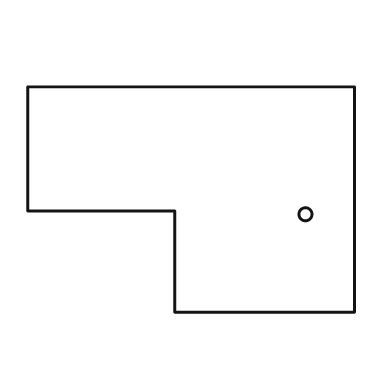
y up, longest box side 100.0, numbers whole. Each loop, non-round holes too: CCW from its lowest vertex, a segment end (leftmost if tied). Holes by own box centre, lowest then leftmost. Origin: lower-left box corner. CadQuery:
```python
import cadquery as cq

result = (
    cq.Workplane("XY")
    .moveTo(45.0, 0.0)
    .lineTo(100.0, 0.0)
    .lineTo(100.0, 69.0)
    .lineTo(0.0, 69.0)
    .lineTo(0.0, 31.0)
    .lineTo(45.0, 31.0)
    .close()
    .moveTo(85.0, 30.0)
    .circle(2.0)
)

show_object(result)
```